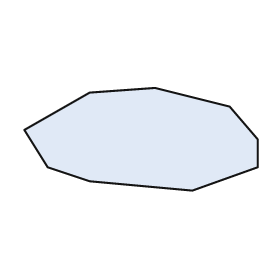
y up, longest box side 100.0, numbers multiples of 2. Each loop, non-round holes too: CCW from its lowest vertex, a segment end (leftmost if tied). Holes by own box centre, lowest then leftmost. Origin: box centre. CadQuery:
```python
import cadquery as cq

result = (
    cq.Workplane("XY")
    .moveTo(22.0, -22.0)
    .lineTo(50.0, -12.0)
    .lineTo(50.0, 0.0)
    .lineTo(38.0, 14.0)
    .lineTo(6.0, 22.0)
    .lineTo(-22.0, 20.0)
    .lineTo(-50.0, 4.0)
    .lineTo(-40.0, -12.0)
    .lineTo(-22.0, -18.0)
    .close()
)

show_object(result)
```